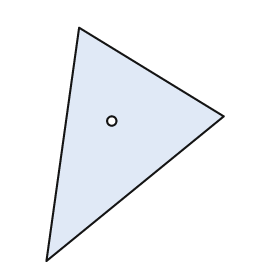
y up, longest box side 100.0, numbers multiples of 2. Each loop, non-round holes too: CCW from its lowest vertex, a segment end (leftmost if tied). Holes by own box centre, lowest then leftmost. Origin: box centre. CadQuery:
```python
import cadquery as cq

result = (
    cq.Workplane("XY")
    .moveTo(-38.0, -50.0)
    .lineTo(38.0, 12.0)
    .lineTo(-24.0, 50.0)
    .close()
    .moveTo(-10.0, 10.0)
    .circle(2.0)
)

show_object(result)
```